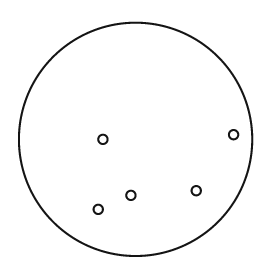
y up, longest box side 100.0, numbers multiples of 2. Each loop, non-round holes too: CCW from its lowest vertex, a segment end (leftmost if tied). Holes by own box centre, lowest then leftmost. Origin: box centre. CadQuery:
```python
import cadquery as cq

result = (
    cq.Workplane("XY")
    .moveTo(0.0, 0.0)
    .circle(50.0)
    .moveTo(-16.0, -30.0)
    .circle(2.0)
    .moveTo(-2.0, -24.0)
    .circle(2.0)
    .moveTo(26.0, -22.0)
    .circle(2.0)
    .moveTo(-14.0, 0.0)
    .circle(2.0)
    .moveTo(42.0, 2.0)
    .circle(2.0)
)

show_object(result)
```